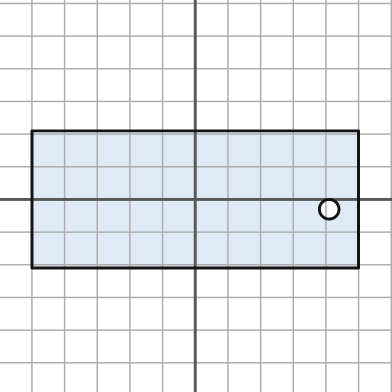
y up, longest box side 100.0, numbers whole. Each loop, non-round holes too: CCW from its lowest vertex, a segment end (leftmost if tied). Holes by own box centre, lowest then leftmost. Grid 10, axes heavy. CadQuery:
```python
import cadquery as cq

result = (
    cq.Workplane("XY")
    .moveTo(-50.0, -21.0)
    .lineTo(50.0, -21.0)
    .lineTo(50.0, 21.0)
    .lineTo(-50.0, 21.0)
    .close()
    .moveTo(41.0, -3.0)
    .circle(3.0)
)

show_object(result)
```